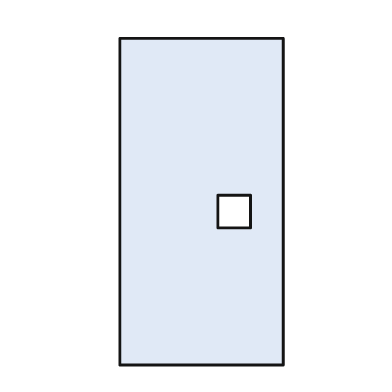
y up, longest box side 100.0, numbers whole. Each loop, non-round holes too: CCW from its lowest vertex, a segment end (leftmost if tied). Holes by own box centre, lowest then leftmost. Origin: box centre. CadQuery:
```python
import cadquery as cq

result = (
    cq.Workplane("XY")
    .moveTo(-25.0, -50.0)
    .lineTo(25.0, -50.0)
    .lineTo(25.0, 50.0)
    .lineTo(-25.0, 50.0)
    .close()
    .moveTo(5.0, -8.0)
    .lineTo(15.0, -8.0)
    .lineTo(15.0, 2.0)
    .lineTo(5.0, 2.0)
    .close()
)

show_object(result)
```